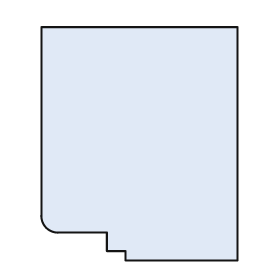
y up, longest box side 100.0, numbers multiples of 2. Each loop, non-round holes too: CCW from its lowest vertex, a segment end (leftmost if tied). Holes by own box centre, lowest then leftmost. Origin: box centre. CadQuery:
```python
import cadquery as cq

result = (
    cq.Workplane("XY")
    .moveTo(-6.0, -50.0)
    .lineTo(42.0, -50.0)
    .lineTo(42.0, 50.0)
    .lineTo(-42.0, 50.0)
    .lineTo(-42.0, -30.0)
    .threePointArc((-40.0, -36.0), (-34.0, -38.0))
    .lineTo(-14.0, -38.0)
    .lineTo(-14.0, -46.0)
    .lineTo(-6.0, -46.0)
    .close()
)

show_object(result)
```